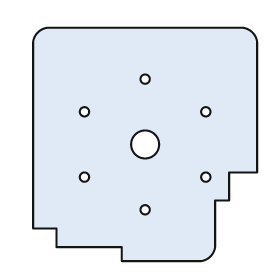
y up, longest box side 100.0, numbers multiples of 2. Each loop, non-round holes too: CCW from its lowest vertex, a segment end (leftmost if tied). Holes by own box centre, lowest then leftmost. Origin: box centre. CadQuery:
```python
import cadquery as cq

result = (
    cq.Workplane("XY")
    .moveTo(-10.0, -50.0)
    .lineTo(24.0, -50.0)
    .threePointArc((28.0, -48.0), (30.0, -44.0))
    .lineTo(30.0, -24.0)
    .lineTo(36.0, -24.0)
    .lineTo(36.0, -12.0)
    .lineTo(48.0, -12.0)
    .lineTo(48.0, 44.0)
    .threePointArc((46.0, 48.0), (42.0, 50.0))
    .lineTo(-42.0, 50.0)
    .threePointArc((-46.0, 48.0), (-48.0, 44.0))
    .lineTo(-48.0, -36.0)
    .lineTo(-38.0, -36.0)
    .lineTo(-38.0, -44.0)
    .lineTo(-10.0, -44.0)
    .close()
    .moveTo(0.0, -28.0)
    .circle(2.0)
    .moveTo(-26.0, -14.0)
    .circle(2.0)
    .moveTo(26.0, -14.0)
    .circle(2.0)
    .moveTo(0.0, 0.0)
    .circle(6.0)
    .moveTo(-26.0, 14.0)
    .circle(2.0)
    .moveTo(26.0, 14.0)
    .circle(2.0)
    .moveTo(0.0, 28.0)
    .circle(2.0)
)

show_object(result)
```